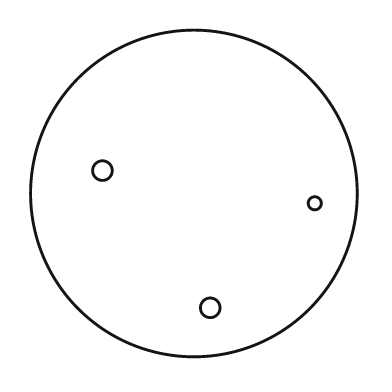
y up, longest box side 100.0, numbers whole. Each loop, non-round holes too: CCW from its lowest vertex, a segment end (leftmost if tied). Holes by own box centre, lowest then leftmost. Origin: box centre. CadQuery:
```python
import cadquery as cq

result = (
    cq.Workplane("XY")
    .moveTo(0.0, 0.0)
    .circle(50.0)
    .moveTo(5.0, -35.0)
    .circle(3.0)
    .moveTo(37.0, -3.0)
    .circle(2.0)
    .moveTo(-28.0, 7.0)
    .circle(3.0)
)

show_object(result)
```